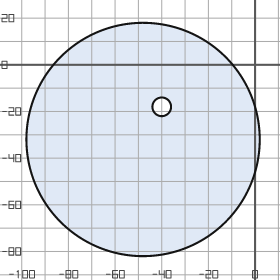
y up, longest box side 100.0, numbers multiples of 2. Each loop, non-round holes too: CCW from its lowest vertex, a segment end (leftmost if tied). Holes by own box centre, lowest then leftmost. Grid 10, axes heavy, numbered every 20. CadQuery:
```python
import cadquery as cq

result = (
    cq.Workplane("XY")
    .moveTo(-48.0, -32.0)
    .circle(50.0)
    .moveTo(-40.0, -18.0)
    .circle(4.0)
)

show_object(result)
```